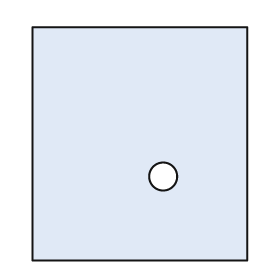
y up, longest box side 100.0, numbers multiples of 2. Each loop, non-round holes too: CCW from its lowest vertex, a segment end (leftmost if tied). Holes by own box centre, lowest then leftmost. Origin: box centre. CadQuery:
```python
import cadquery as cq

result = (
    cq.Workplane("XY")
    .moveTo(-46.0, -50.0)
    .lineTo(46.0, -50.0)
    .lineTo(46.0, 50.0)
    .lineTo(-46.0, 50.0)
    .close()
    .moveTo(10.0, -14.0)
    .circle(6.0)
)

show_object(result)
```